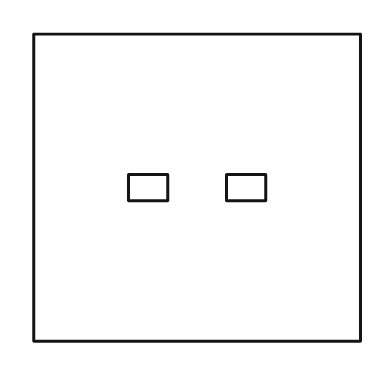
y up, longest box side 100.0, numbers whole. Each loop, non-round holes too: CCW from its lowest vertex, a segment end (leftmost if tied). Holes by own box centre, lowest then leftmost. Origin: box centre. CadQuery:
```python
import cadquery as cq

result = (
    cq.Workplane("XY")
    .moveTo(-50.0, -47.0)
    .lineTo(50.0, -47.0)
    .lineTo(50.0, 47.0)
    .lineTo(-50.0, 47.0)
    .close()
    .moveTo(-21.0, -4.0)
    .lineTo(-9.0, -4.0)
    .lineTo(-9.0, 4.0)
    .lineTo(-21.0, 4.0)
    .close()
    .moveTo(9.0, -4.0)
    .lineTo(21.0, -4.0)
    .lineTo(21.0, 4.0)
    .lineTo(9.0, 4.0)
    .close()
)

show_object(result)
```